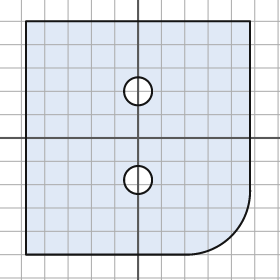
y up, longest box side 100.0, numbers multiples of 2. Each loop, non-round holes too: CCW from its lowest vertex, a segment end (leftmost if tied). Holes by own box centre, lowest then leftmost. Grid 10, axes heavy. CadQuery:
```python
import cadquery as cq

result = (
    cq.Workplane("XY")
    .moveTo(-48.0, -50.0)
    .lineTo(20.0, -50.0)
    .threePointArc((40.0, -42.0), (48.0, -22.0))
    .lineTo(48.0, 50.0)
    .lineTo(-48.0, 50.0)
    .close()
    .moveTo(0.0, -18.0)
    .circle(6.0)
    .moveTo(0.0, 20.0)
    .circle(6.0)
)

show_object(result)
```